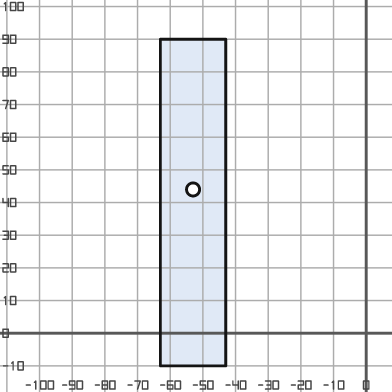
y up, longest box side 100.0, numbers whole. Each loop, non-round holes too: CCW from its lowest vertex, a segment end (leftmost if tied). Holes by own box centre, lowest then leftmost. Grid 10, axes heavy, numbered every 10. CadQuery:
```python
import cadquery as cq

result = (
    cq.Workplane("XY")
    .moveTo(-63.0, -10.0)
    .lineTo(-43.0, -10.0)
    .lineTo(-43.0, 90.0)
    .lineTo(-63.0, 90.0)
    .close()
    .moveTo(-53.0, 44.0)
    .circle(2.0)
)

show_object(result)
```